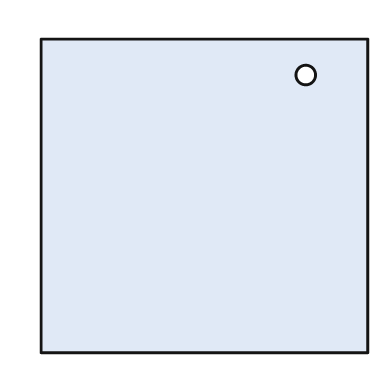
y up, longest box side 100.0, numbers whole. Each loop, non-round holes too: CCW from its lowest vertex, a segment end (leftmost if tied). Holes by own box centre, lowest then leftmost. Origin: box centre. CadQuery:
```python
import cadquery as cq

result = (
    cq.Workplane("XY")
    .moveTo(-50.0, -48.0)
    .lineTo(50.0, -48.0)
    .lineTo(50.0, 48.0)
    .lineTo(-50.0, 48.0)
    .close()
    .moveTo(31.0, 37.0)
    .circle(3.0)
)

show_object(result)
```